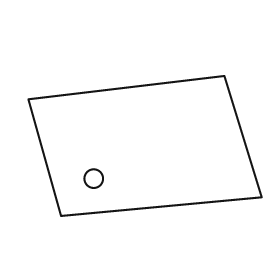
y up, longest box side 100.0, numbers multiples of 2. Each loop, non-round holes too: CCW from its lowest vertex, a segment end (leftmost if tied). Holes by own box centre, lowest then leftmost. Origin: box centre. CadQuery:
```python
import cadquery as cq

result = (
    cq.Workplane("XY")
    .moveTo(-36.0, -30.0)
    .lineTo(50.0, -22.0)
    .lineTo(34.0, 30.0)
    .lineTo(-50.0, 20.0)
    .close()
    .moveTo(-22.0, -14.0)
    .circle(4.0)
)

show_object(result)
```